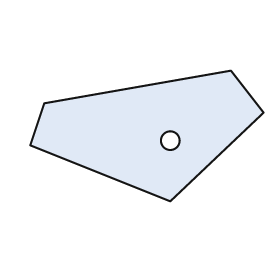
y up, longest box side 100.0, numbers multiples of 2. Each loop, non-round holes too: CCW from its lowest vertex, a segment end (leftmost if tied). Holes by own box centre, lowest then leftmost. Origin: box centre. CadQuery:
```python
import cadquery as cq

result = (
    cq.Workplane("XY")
    .moveTo(10.0, -28.0)
    .lineTo(50.0, 10.0)
    .lineTo(36.0, 28.0)
    .lineTo(-44.0, 14.0)
    .lineTo(-50.0, -4.0)
    .close()
    .moveTo(10.0, -2.0)
    .circle(4.0)
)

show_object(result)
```